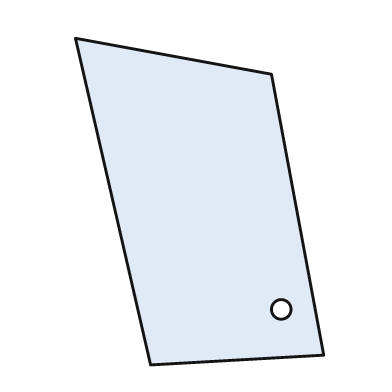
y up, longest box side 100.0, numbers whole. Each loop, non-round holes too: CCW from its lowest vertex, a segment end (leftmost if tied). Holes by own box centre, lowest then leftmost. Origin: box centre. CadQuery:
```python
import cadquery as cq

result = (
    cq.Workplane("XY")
    .moveTo(-15.0, -50.0)
    .lineTo(38.0, -47.0)
    .lineTo(22.0, 39.0)
    .lineTo(-38.0, 50.0)
    .close()
    .moveTo(25.0, -33.0)
    .circle(3.0)
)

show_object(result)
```